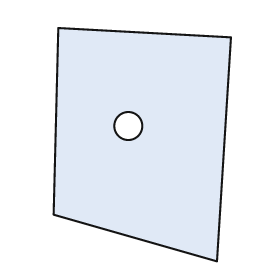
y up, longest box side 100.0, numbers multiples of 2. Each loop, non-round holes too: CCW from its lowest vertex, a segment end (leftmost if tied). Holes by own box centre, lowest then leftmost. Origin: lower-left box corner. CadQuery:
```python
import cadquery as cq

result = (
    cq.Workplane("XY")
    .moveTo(70.0, 0.0)
    .lineTo(76.0, 96.0)
    .lineTo(2.0, 100.0)
    .lineTo(0.0, 20.0)
    .close()
    .moveTo(32.0, 58.0)
    .circle(6.0)
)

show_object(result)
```